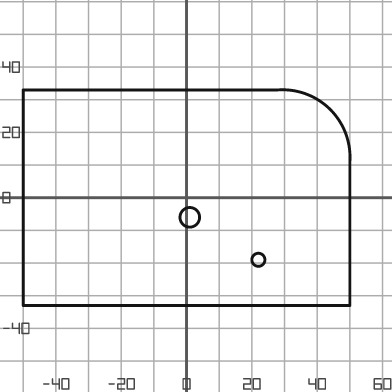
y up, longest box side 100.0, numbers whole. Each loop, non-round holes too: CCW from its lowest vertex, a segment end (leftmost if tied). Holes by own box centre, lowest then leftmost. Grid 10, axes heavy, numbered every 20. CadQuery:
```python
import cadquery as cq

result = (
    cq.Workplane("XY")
    .moveTo(-50.0, -33.0)
    .lineTo(50.0, -33.0)
    .lineTo(50.0, 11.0)
    .threePointArc((44.0, 27.0), (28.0, 33.0))
    .lineTo(-50.0, 33.0)
    .close()
    .moveTo(22.0, -19.0)
    .circle(2.0)
    .moveTo(1.0, -6.0)
    .circle(3.0)
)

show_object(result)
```